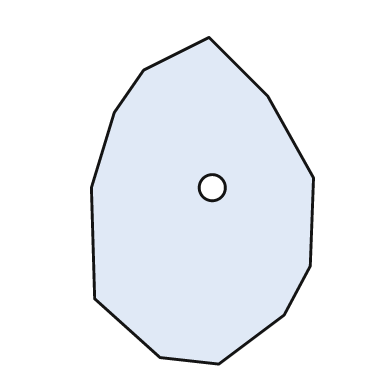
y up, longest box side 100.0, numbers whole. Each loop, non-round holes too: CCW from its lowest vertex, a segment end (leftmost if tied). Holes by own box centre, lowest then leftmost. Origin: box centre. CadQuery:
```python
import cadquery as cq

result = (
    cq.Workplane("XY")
    .moveTo(5.0, -50.0)
    .lineTo(25.0, -35.0)
    .lineTo(33.0, -20.0)
    .lineTo(34.0, 7.0)
    .lineTo(20.0, 32.0)
    .lineTo(2.0, 50.0)
    .lineTo(-18.0, 40.0)
    .lineTo(-27.0, 27.0)
    .lineTo(-34.0, 4.0)
    .lineTo(-33.0, -30.0)
    .lineTo(-13.0, -48.0)
    .close()
    .moveTo(3.0, 4.0)
    .circle(4.0)
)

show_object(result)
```